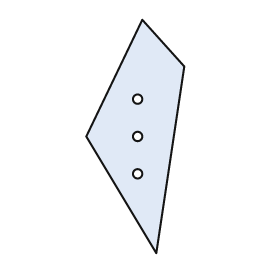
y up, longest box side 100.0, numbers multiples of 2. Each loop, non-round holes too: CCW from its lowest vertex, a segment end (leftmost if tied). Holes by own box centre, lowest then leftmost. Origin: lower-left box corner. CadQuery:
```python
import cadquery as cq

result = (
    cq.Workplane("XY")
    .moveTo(30.0, 0.0)
    .lineTo(42.0, 80.0)
    .lineTo(24.0, 100.0)
    .lineTo(0.0, 50.0)
    .close()
    .moveTo(22.0, 34.0)
    .circle(2.0)
    .moveTo(22.0, 50.0)
    .circle(2.0)
    .moveTo(22.0, 66.0)
    .circle(2.0)
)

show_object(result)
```